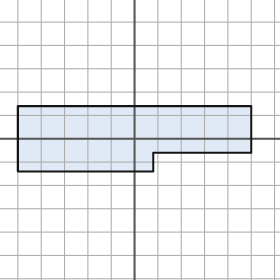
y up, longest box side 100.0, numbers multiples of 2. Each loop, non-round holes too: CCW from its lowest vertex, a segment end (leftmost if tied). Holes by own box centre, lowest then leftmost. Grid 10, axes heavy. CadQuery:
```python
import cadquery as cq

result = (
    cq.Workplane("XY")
    .moveTo(-50.0, -14.0)
    .lineTo(8.0, -14.0)
    .lineTo(8.0, -6.0)
    .lineTo(50.0, -6.0)
    .lineTo(50.0, 14.0)
    .lineTo(-50.0, 14.0)
    .close()
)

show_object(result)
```